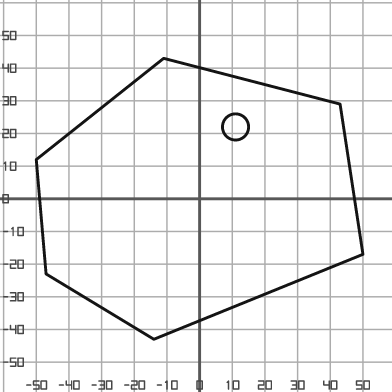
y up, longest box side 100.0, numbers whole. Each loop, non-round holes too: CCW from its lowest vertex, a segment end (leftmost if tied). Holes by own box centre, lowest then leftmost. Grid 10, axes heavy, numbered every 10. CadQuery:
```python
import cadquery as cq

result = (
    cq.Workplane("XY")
    .moveTo(-14.0, -43.0)
    .lineTo(50.0, -17.0)
    .lineTo(43.0, 29.0)
    .lineTo(-11.0, 43.0)
    .lineTo(-50.0, 12.0)
    .lineTo(-47.0, -23.0)
    .close()
    .moveTo(11.0, 22.0)
    .circle(4.0)
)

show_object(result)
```